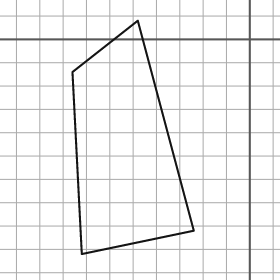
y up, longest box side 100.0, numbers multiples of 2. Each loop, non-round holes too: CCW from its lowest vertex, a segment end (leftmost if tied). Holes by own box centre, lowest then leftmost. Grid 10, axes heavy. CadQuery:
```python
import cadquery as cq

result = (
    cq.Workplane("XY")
    .moveTo(-72.0, -92.0)
    .lineTo(-24.0, -82.0)
    .lineTo(-48.0, 8.0)
    .lineTo(-76.0, -14.0)
    .close()
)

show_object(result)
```